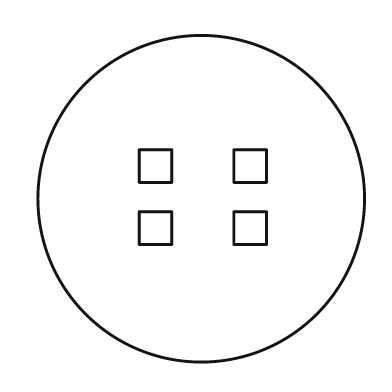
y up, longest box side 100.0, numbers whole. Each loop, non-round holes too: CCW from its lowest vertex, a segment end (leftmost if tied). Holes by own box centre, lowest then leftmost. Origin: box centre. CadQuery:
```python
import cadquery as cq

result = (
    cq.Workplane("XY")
    .moveTo(0.0, 0.0)
    .circle(50.0)
    .moveTo(-19.0, -14.0)
    .lineTo(-9.0, -14.0)
    .lineTo(-9.0, -4.0)
    .lineTo(-19.0, -4.0)
    .close()
    .moveTo(10.0, -14.0)
    .lineTo(20.0, -14.0)
    .lineTo(20.0, -4.0)
    .lineTo(10.0, -4.0)
    .close()
    .moveTo(-19.0, 5.0)
    .lineTo(-9.0, 5.0)
    .lineTo(-9.0, 15.0)
    .lineTo(-19.0, 15.0)
    .close()
    .moveTo(10.0, 5.0)
    .lineTo(20.0, 5.0)
    .lineTo(20.0, 15.0)
    .lineTo(10.0, 15.0)
    .close()
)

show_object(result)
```